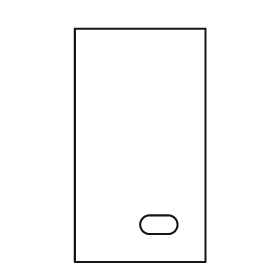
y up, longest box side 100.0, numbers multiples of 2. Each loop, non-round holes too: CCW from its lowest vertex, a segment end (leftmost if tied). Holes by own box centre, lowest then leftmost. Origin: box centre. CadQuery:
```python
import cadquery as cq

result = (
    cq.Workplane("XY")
    .moveTo(-28.0, -50.0)
    .lineTo(28.0, -50.0)
    .lineTo(28.0, 50.0)
    .lineTo(-28.0, 50.0)
    .close()
    .moveTo(4.0, -38.0)
    .lineTo(12.0, -38.0)
    .threePointArc((16.0, -34.0), (12.0, -30.0))
    .lineTo(4.0, -30.0)
    .threePointArc((0.0, -34.0), (4.0, -38.0))
    .close()
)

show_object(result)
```